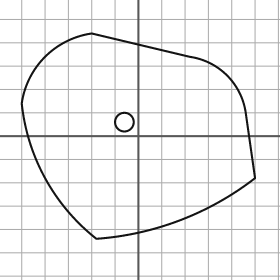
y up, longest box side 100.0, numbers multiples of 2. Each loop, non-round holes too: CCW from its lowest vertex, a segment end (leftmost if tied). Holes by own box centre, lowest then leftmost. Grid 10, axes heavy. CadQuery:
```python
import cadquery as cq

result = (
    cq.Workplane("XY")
    .moveTo(-18.0, -44.0)
    .threePointArc((18.0, -36.0), (50.0, -18.0))
    .lineTo(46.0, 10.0)
    .threePointArc((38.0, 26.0), (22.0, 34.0))
    .lineTo(-20.0, 44.0)
    .threePointArc((-40.0, 34.0), (-50.0, 14.0))
    .threePointArc((-40.0, -18.0), (-18.0, -44.0))
    .close()
    .moveTo(-6.0, 6.0)
    .circle(4.0)
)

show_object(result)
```